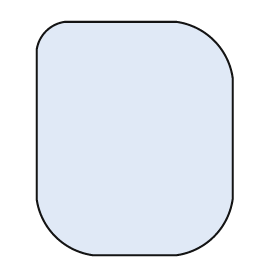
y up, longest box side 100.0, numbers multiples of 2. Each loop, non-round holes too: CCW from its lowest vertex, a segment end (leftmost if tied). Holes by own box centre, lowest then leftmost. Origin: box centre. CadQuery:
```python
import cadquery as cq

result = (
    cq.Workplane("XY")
    .moveTo(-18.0, -50.0)
    .lineTo(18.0, -50.0)
    .threePointArc((34.0, -42.0), (42.0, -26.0))
    .lineTo(42.0, 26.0)
    .threePointArc((34.0, 42.0), (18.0, 50.0))
    .lineTo(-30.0, 50.0)
    .threePointArc((-38.0, 46.0), (-42.0, 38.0))
    .lineTo(-42.0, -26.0)
    .threePointArc((-34.0, -42.0), (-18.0, -50.0))
    .close()
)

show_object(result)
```